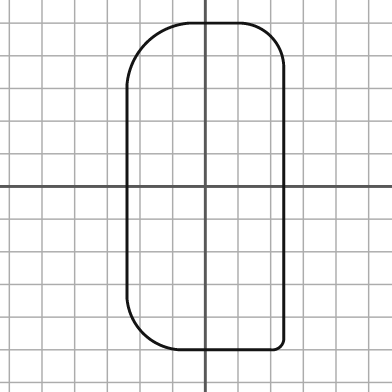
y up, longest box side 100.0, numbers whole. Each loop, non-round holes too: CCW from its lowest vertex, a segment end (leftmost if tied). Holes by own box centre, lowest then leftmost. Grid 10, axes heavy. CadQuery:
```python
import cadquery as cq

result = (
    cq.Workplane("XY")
    .moveTo(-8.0, -50.0)
    .lineTo(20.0, -50.0)
    .threePointArc((23.0, -49.0), (24.0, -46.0))
    .lineTo(24.0, 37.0)
    .threePointArc((20.0, 46.0), (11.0, 50.0))
    .lineTo(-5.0, 50.0)
    .threePointArc((-18.0, 44.0), (-24.0, 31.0))
    .lineTo(-24.0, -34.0)
    .threePointArc((-19.0, -45.0), (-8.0, -50.0))
    .close()
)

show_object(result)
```